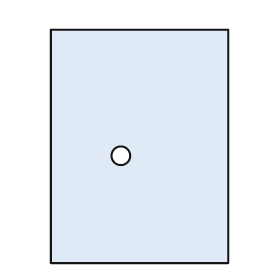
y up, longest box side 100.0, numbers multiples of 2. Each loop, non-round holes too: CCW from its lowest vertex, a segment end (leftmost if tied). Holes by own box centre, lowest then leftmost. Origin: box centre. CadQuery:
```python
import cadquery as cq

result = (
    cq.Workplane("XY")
    .moveTo(-38.0, -50.0)
    .lineTo(38.0, -50.0)
    .lineTo(38.0, 50.0)
    .lineTo(-38.0, 50.0)
    .close()
    .moveTo(-8.0, -4.0)
    .circle(4.0)
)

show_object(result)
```